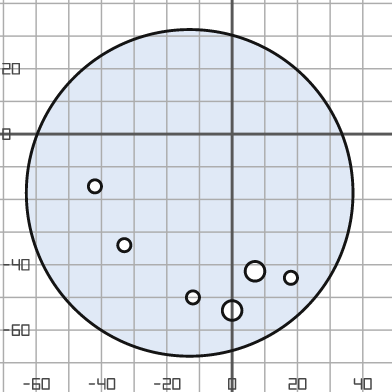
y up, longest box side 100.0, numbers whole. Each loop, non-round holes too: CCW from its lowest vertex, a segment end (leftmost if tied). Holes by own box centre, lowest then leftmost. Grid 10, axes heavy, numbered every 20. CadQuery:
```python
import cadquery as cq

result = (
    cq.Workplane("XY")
    .moveTo(-13.0, -18.0)
    .circle(50.0)
    .moveTo(0.0, -54.0)
    .circle(3.0)
    .moveTo(-12.0, -50.0)
    .circle(2.0)
    .moveTo(18.0, -44.0)
    .circle(2.0)
    .moveTo(7.0, -42.0)
    .circle(3.0)
    .moveTo(-33.0, -34.0)
    .circle(2.0)
    .moveTo(-42.0, -16.0)
    .circle(2.0)
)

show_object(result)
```